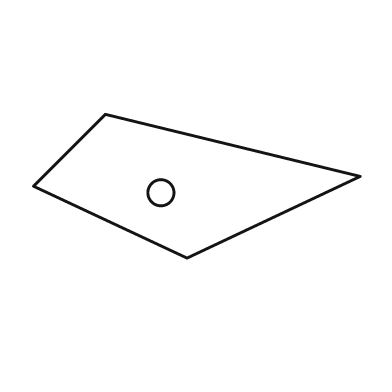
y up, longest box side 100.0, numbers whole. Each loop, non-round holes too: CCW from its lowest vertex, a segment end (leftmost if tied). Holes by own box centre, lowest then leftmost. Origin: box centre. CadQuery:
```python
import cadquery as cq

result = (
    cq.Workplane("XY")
    .moveTo(-3.0, -22.0)
    .lineTo(50.0, 3.0)
    .lineTo(-28.0, 22.0)
    .lineTo(-50.0, 0.0)
    .close()
    .moveTo(-11.0, -2.0)
    .circle(4.0)
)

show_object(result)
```